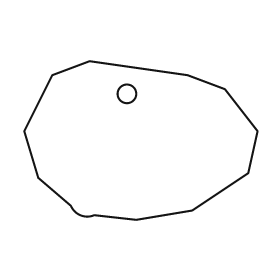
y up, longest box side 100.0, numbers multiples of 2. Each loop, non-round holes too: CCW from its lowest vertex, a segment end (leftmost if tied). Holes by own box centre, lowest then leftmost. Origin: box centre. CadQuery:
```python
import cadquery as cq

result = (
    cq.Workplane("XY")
    .moveTo(-2.0, -34.0)
    .lineTo(22.0, -30.0)
    .lineTo(46.0, -14.0)
    .lineTo(50.0, 4.0)
    .lineTo(36.0, 22.0)
    .lineTo(20.0, 28.0)
    .lineTo(-22.0, 34.0)
    .lineTo(-38.0, 28.0)
    .lineTo(-50.0, 4.0)
    .lineTo(-44.0, -16.0)
    .lineTo(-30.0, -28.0)
    .threePointArc((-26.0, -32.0), (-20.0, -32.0))
    .close()
    .moveTo(-6.0, 20.0)
    .circle(4.0)
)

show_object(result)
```